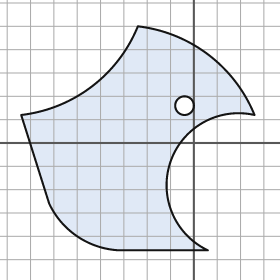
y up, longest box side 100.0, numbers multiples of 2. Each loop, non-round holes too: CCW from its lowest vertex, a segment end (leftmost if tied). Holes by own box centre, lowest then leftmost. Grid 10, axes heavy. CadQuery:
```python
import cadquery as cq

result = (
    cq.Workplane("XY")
    .moveTo(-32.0, -46.0)
    .lineTo(6.0, -46.0)
    .threePointArc((-10.0, -8.0), (26.0, 12.0))
    .threePointArc((6.0, 38.0), (-24.0, 50.0))
    .threePointArc((-44.0, 24.0), (-74.0, 12.0))
    .lineTo(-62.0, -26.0)
    .threePointArc((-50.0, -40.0), (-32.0, -46.0))
    .close()
    .moveTo(-4.0, 16.0)
    .circle(4.0)
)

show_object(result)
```